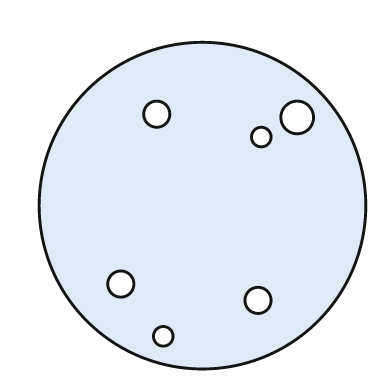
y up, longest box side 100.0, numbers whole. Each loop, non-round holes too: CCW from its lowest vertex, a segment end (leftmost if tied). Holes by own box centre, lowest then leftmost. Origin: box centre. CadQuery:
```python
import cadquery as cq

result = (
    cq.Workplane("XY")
    .moveTo(0.0, 0.0)
    .circle(50.0)
    .moveTo(-12.0, -40.0)
    .circle(3.0)
    .moveTo(17.0, -29.0)
    .circle(4.0)
    .moveTo(-25.0, -24.0)
    .circle(4.0)
    .moveTo(18.0, 21.0)
    .circle(3.0)
    .moveTo(29.0, 27.0)
    .circle(5.0)
    .moveTo(-14.0, 28.0)
    .circle(4.0)
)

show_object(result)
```